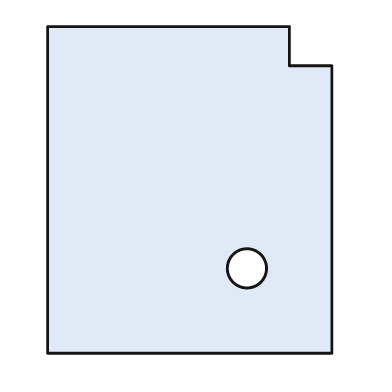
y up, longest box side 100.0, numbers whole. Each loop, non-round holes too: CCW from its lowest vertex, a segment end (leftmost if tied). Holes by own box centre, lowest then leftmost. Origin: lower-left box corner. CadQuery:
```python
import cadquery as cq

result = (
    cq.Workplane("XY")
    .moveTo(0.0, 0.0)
    .lineTo(87.0, 0.0)
    .lineTo(87.0, 88.0)
    .lineTo(74.0, 88.0)
    .lineTo(74.0, 100.0)
    .lineTo(0.0, 100.0)
    .close()
    .moveTo(61.0, 26.0)
    .circle(6.0)
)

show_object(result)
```